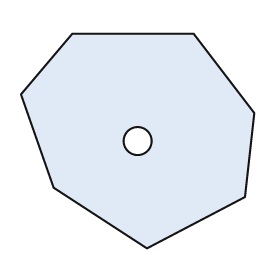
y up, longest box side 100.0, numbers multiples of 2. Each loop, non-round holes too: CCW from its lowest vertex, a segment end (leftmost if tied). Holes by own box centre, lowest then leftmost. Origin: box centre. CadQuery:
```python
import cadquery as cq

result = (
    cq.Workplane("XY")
    .moveTo(4.0, -46.0)
    .lineTo(46.0, -24.0)
    .lineTo(50.0, 12.0)
    .lineTo(24.0, 46.0)
    .lineTo(-28.0, 46.0)
    .lineTo(-50.0, 20.0)
    .lineTo(-36.0, -20.0)
    .close()
    .moveTo(0.0, 0.0)
    .circle(6.0)
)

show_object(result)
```